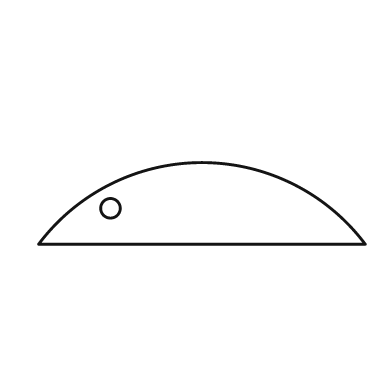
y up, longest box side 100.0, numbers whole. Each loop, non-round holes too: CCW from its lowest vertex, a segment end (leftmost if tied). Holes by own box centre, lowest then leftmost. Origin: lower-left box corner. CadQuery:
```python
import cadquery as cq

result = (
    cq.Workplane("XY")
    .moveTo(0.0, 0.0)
    .lineTo(100.0, 0.0)
    .threePointArc((50.0, 25.0), (0.0, 0.0))
    .close()
    .moveTo(22.0, 11.0)
    .circle(3.0)
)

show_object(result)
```